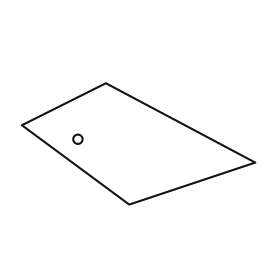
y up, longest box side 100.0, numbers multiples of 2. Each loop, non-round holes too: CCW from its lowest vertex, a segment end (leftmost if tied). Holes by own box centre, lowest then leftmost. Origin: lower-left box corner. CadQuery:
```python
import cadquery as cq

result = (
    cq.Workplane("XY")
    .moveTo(46.0, 0.0)
    .lineTo(100.0, 18.0)
    .lineTo(36.0, 52.0)
    .lineTo(0.0, 34.0)
    .close()
    .moveTo(24.0, 28.0)
    .circle(2.0)
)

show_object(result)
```